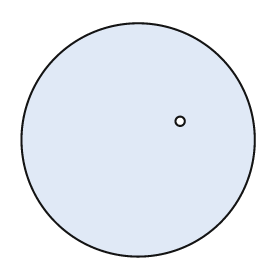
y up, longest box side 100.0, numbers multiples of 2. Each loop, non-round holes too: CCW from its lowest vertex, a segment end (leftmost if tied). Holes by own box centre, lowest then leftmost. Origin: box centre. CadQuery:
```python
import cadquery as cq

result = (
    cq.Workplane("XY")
    .moveTo(0.0, 0.0)
    .circle(50.0)
    .moveTo(18.0, 8.0)
    .circle(2.0)
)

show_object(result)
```